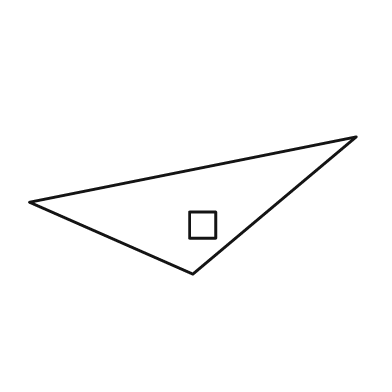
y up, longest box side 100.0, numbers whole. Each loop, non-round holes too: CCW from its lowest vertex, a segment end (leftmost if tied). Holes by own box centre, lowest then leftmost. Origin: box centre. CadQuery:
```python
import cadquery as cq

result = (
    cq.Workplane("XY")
    .moveTo(0.0, -21.0)
    .lineTo(50.0, 21.0)
    .lineTo(-50.0, 1.0)
    .close()
    .moveTo(-1.0, -10.0)
    .lineTo(7.0, -10.0)
    .lineTo(7.0, -2.0)
    .lineTo(-1.0, -2.0)
    .close()
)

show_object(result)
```